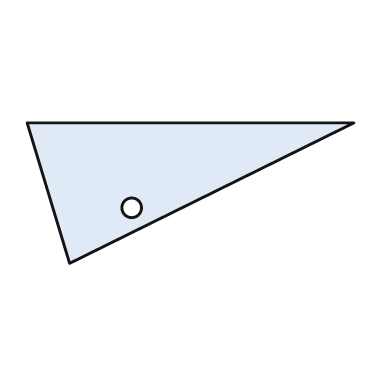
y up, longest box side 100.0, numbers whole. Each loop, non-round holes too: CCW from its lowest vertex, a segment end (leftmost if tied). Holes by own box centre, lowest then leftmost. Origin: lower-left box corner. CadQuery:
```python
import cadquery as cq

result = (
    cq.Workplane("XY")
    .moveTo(13.0, 0.0)
    .lineTo(100.0, 43.0)
    .lineTo(0.0, 43.0)
    .close()
    .moveTo(32.0, 17.0)
    .circle(3.0)
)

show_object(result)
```